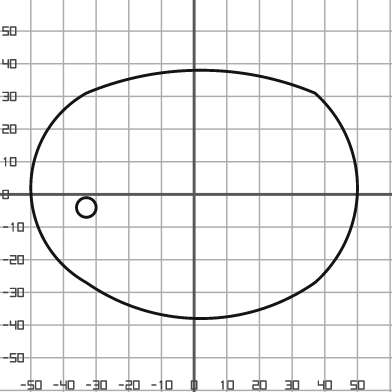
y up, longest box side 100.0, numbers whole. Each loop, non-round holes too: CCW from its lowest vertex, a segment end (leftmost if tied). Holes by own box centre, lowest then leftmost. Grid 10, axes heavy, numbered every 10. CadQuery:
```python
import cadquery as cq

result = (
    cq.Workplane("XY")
    .moveTo(-33.0, -27.0)
    .threePointArc((2.0, -38.0), (37.0, -27.0))
    .threePointArc((50.0, 2.0), (37.0, 31.0))
    .threePointArc((2.0, 38.0), (-33.0, 31.0))
    .threePointArc((-50.0, 2.0), (-33.0, -27.0))
    .close()
    .moveTo(-33.0, -4.0)
    .circle(3.0)
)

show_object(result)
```